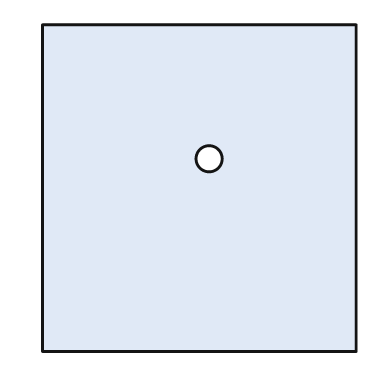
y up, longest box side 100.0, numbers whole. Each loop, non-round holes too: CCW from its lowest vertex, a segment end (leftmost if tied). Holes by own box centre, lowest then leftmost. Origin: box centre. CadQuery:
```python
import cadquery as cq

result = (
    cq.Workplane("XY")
    .moveTo(-48.0, -50.0)
    .lineTo(48.0, -50.0)
    .lineTo(48.0, 50.0)
    .lineTo(-48.0, 50.0)
    .close()
    .moveTo(3.0, 9.0)
    .circle(4.0)
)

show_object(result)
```